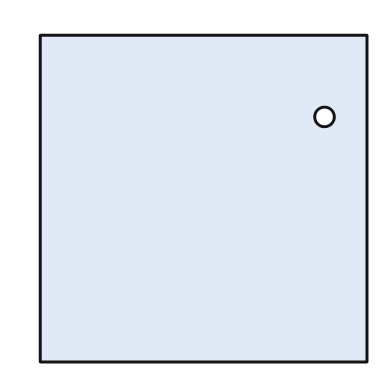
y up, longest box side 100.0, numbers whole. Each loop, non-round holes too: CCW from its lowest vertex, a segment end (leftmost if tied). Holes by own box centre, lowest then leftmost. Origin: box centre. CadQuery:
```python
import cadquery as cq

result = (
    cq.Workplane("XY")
    .moveTo(-50.0, -50.0)
    .lineTo(50.0, -50.0)
    .lineTo(50.0, 50.0)
    .lineTo(-50.0, 50.0)
    .close()
    .moveTo(37.0, 25.0)
    .circle(3.0)
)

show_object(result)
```